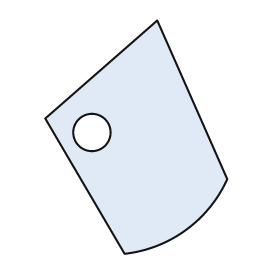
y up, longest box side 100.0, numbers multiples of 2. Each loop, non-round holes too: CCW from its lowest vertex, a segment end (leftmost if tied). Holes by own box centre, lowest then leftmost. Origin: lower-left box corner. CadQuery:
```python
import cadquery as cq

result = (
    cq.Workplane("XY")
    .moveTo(34.0, 0.0)
    .threePointArc((60.0, 10.0), (78.0, 32.0))
    .lineTo(48.0, 100.0)
    .lineTo(0.0, 58.0)
    .close()
    .moveTo(20.0, 52.0)
    .circle(8.0)
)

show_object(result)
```